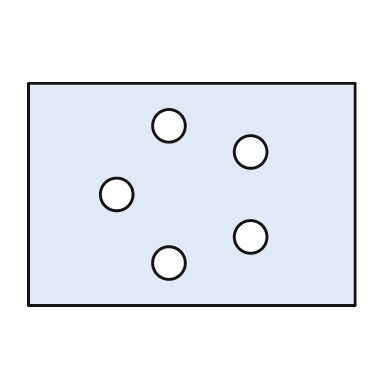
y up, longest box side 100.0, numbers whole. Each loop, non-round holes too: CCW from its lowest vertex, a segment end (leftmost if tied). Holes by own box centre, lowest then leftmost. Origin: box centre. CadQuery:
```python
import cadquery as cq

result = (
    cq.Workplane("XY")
    .moveTo(-50.0, -34.0)
    .lineTo(50.0, -34.0)
    .lineTo(50.0, 34.0)
    .lineTo(-50.0, 34.0)
    .close()
    .moveTo(-7.0, -21.0)
    .circle(5.0)
    .moveTo(18.0, -13.0)
    .circle(5.0)
    .moveTo(-23.0, 0.0)
    .circle(5.0)
    .moveTo(18.0, 13.0)
    .circle(5.0)
    .moveTo(-7.0, 21.0)
    .circle(5.0)
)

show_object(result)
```